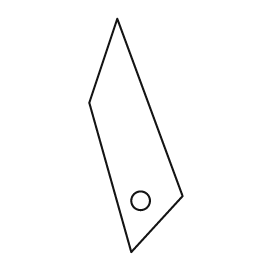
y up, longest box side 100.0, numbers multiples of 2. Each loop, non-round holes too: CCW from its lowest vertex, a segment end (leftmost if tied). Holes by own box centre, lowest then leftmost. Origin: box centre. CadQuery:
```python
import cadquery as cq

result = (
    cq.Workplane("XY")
    .moveTo(-2.0, -50.0)
    .lineTo(20.0, -26.0)
    .lineTo(-8.0, 50.0)
    .lineTo(-20.0, 14.0)
    .close()
    .moveTo(2.0, -28.0)
    .circle(4.0)
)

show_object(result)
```